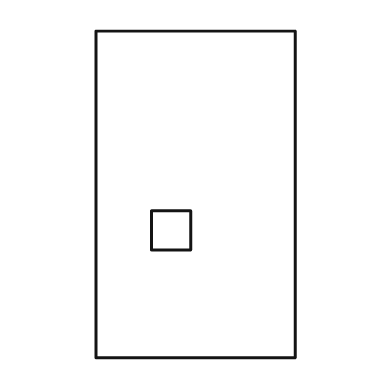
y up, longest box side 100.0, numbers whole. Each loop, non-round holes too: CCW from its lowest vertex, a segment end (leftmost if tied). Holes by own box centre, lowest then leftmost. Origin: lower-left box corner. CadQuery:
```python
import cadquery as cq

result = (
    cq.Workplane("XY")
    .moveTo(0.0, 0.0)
    .lineTo(61.0, 0.0)
    .lineTo(61.0, 100.0)
    .lineTo(0.0, 100.0)
    .close()
    .moveTo(17.0, 33.0)
    .lineTo(29.0, 33.0)
    .lineTo(29.0, 45.0)
    .lineTo(17.0, 45.0)
    .close()
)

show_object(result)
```